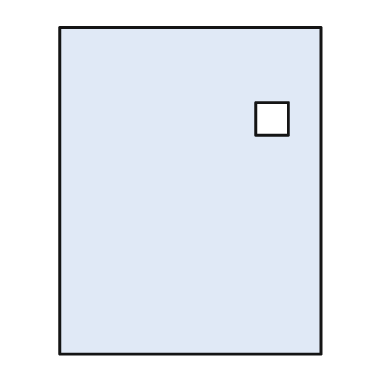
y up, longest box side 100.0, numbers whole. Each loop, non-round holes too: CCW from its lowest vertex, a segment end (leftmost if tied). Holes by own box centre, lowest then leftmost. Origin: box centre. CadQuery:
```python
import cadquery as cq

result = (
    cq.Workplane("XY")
    .moveTo(-40.0, -50.0)
    .lineTo(40.0, -50.0)
    .lineTo(40.0, 50.0)
    .lineTo(-40.0, 50.0)
    .close()
    .moveTo(20.0, 17.0)
    .lineTo(30.0, 17.0)
    .lineTo(30.0, 27.0)
    .lineTo(20.0, 27.0)
    .close()
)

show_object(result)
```